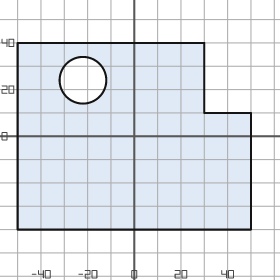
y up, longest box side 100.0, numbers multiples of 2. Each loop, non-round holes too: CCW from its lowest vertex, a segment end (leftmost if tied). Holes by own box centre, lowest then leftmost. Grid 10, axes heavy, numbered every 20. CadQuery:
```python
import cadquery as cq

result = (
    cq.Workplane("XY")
    .moveTo(-50.0, -40.0)
    .lineTo(50.0, -40.0)
    .lineTo(50.0, 10.0)
    .lineTo(30.0, 10.0)
    .lineTo(30.0, 40.0)
    .lineTo(-50.0, 40.0)
    .close()
    .moveTo(-22.0, 24.0)
    .circle(10.0)
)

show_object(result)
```